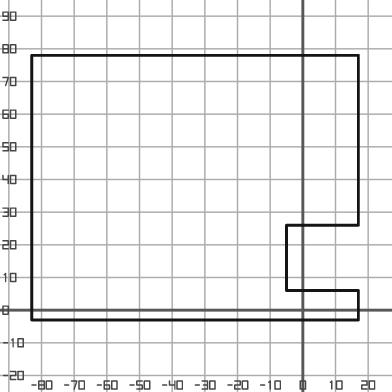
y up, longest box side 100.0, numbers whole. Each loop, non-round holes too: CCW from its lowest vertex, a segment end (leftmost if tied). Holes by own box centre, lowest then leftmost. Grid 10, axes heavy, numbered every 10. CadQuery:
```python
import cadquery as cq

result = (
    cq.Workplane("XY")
    .moveTo(-83.0, -3.0)
    .lineTo(17.0, -3.0)
    .lineTo(17.0, 6.0)
    .lineTo(-5.0, 6.0)
    .lineTo(-5.0, 26.0)
    .lineTo(17.0, 26.0)
    .lineTo(17.0, 78.0)
    .lineTo(-83.0, 78.0)
    .close()
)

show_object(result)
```